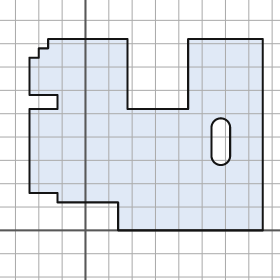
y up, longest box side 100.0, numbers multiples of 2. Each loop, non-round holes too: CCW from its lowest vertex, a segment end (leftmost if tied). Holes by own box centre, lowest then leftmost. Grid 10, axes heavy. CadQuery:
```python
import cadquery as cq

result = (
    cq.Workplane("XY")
    .moveTo(14.0, 0.0)
    .lineTo(76.0, 0.0)
    .lineTo(76.0, 82.0)
    .lineTo(44.0, 82.0)
    .lineTo(44.0, 52.0)
    .lineTo(18.0, 52.0)
    .lineTo(18.0, 82.0)
    .lineTo(-16.0, 82.0)
    .lineTo(-16.0, 78.0)
    .lineTo(-20.0, 78.0)
    .lineTo(-20.0, 74.0)
    .lineTo(-24.0, 74.0)
    .lineTo(-24.0, 58.0)
    .lineTo(-12.0, 58.0)
    .lineTo(-12.0, 52.0)
    .lineTo(-24.0, 52.0)
    .lineTo(-24.0, 16.0)
    .lineTo(-12.0, 16.0)
    .lineTo(-12.0, 12.0)
    .lineTo(14.0, 12.0)
    .close()
    .moveTo(54.0, 32.0)
    .threePointArc((58.0, 28.0), (62.0, 32.0))
    .lineTo(62.0, 44.0)
    .threePointArc((58.0, 48.0), (54.0, 44.0))
    .close()
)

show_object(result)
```